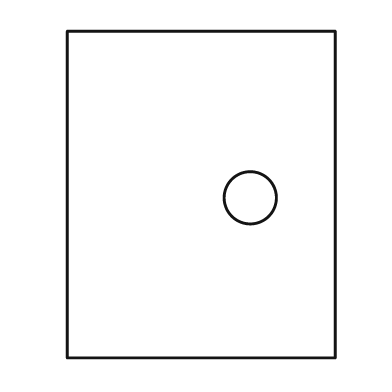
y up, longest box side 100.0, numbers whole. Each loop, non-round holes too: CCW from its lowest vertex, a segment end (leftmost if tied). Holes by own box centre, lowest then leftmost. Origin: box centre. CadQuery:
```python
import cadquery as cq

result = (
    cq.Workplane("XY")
    .moveTo(-41.0, -50.0)
    .lineTo(41.0, -50.0)
    .lineTo(41.0, 50.0)
    .lineTo(-41.0, 50.0)
    .close()
    .moveTo(15.0, -1.0)
    .circle(8.0)
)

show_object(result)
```